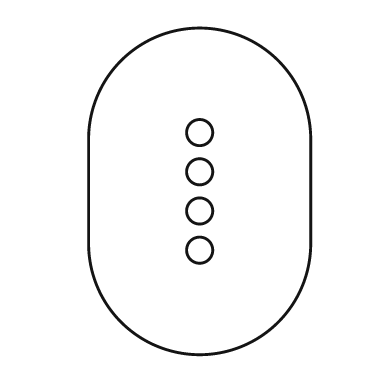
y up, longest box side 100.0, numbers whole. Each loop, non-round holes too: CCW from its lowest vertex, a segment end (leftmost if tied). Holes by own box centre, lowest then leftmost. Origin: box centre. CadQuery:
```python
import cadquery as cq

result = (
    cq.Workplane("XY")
    .moveTo(-34.0, -16.0)
    .threePointArc((0.0, -50.0), (34.0, -16.0))
    .lineTo(34.0, 16.0)
    .threePointArc((0.0, 50.0), (-34.0, 16.0))
    .close()
    .moveTo(0.0, -18.0)
    .circle(4.0)
    .moveTo(0.0, -6.0)
    .circle(4.0)
    .moveTo(0.0, 6.0)
    .circle(4.0)
    .moveTo(0.0, 18.0)
    .circle(4.0)
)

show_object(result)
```